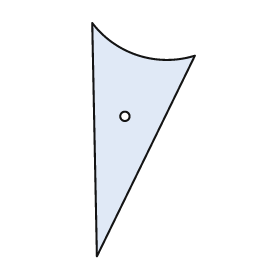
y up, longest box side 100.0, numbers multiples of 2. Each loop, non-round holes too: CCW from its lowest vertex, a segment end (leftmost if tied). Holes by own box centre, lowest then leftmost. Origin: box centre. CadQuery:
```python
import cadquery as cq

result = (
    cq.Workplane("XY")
    .moveTo(-20.0, -50.0)
    .lineTo(22.0, 36.0)
    .threePointArc((-2.0, 36.0), (-22.0, 50.0))
    .close()
    .moveTo(-8.0, 10.0)
    .circle(2.0)
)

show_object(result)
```